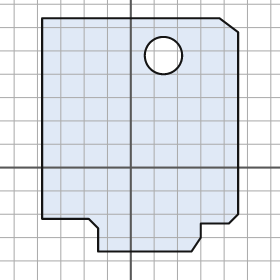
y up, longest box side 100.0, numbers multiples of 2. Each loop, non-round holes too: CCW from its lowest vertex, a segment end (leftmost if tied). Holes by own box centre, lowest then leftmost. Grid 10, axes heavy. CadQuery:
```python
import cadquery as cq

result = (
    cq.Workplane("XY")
    .moveTo(-14.0, -36.0)
    .lineTo(26.0, -36.0)
    .lineTo(30.0, -30.0)
    .lineTo(30.0, -24.0)
    .lineTo(42.0, -24.0)
    .lineTo(46.0, -20.0)
    .lineTo(46.0, 58.0)
    .lineTo(38.0, 64.0)
    .lineTo(-38.0, 64.0)
    .lineTo(-38.0, -22.0)
    .lineTo(-18.0, -22.0)
    .lineTo(-14.0, -26.0)
    .close()
    .moveTo(14.0, 48.0)
    .circle(8.0)
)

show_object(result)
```